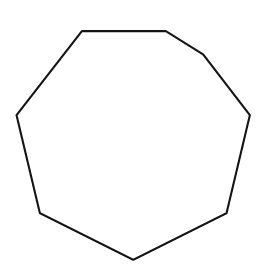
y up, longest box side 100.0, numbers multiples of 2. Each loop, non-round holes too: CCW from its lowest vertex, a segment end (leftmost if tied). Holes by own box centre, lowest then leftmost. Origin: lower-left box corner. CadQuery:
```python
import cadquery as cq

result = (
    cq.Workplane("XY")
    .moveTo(50.0, 0.0)
    .lineTo(90.0, 20.0)
    .lineTo(100.0, 62.0)
    .lineTo(80.0, 88.0)
    .lineTo(64.0, 98.0)
    .lineTo(28.0, 98.0)
    .lineTo(0.0, 62.0)
    .lineTo(10.0, 20.0)
    .close()
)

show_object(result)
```